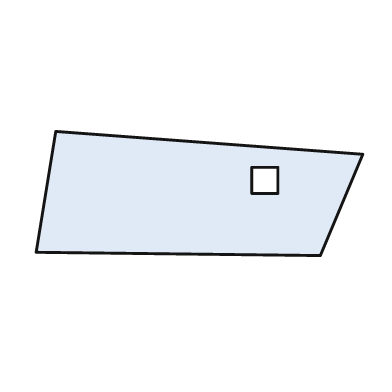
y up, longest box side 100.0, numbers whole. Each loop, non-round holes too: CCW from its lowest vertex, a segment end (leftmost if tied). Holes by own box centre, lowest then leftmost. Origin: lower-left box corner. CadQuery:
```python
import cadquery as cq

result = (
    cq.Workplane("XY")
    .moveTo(87.0, 0.0)
    .lineTo(100.0, 31.0)
    .lineTo(6.0, 38.0)
    .lineTo(0.0, 1.0)
    .close()
    .moveTo(66.0, 19.0)
    .lineTo(74.0, 19.0)
    .lineTo(74.0, 27.0)
    .lineTo(66.0, 27.0)
    .close()
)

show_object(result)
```